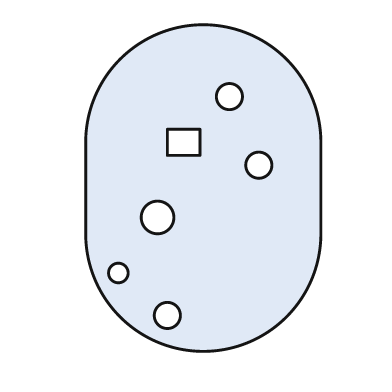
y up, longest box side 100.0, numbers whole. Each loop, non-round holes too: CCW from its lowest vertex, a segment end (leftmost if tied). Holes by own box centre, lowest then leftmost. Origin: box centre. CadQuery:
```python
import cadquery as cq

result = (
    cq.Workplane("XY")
    .moveTo(-36.0, -14.0)
    .threePointArc((0.0, -50.0), (36.0, -14.0))
    .lineTo(36.0, 14.0)
    .threePointArc((0.0, 50.0), (-36.0, 14.0))
    .close()
    .moveTo(-11.0, -39.0)
    .circle(4.0)
    .moveTo(-26.0, -26.0)
    .circle(3.0)
    .moveTo(-14.0, -9.0)
    .circle(5.0)
    .moveTo(17.0, 7.0)
    .circle(4.0)
    .moveTo(-11.0, 10.0)
    .lineTo(-1.0, 10.0)
    .lineTo(-1.0, 18.0)
    .lineTo(-11.0, 18.0)
    .close()
    .moveTo(8.0, 28.0)
    .circle(4.0)
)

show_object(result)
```